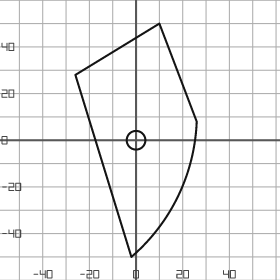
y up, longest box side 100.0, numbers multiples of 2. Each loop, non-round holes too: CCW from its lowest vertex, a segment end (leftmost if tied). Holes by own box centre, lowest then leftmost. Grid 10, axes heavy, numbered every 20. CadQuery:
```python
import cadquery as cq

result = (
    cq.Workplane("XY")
    .moveTo(-2.0, -50.0)
    .threePointArc((18.0, -24.0), (26.0, 8.0))
    .lineTo(10.0, 50.0)
    .lineTo(-26.0, 28.0)
    .close()
    .moveTo(0.0, 0.0)
    .circle(4.0)
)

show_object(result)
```